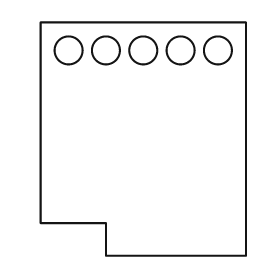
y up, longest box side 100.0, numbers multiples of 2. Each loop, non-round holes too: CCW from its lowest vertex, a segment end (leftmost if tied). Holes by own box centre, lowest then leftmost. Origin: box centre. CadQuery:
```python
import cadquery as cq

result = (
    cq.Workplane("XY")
    .moveTo(-16.0, -50.0)
    .lineTo(44.0, -50.0)
    .lineTo(44.0, 50.0)
    .lineTo(-44.0, 50.0)
    .lineTo(-44.0, -36.0)
    .lineTo(-16.0, -36.0)
    .close()
    .moveTo(-32.0, 38.0)
    .circle(6.0)
    .moveTo(-16.0, 38.0)
    .circle(6.0)
    .moveTo(0.0, 38.0)
    .circle(6.0)
    .moveTo(16.0, 38.0)
    .circle(6.0)
    .moveTo(32.0, 38.0)
    .circle(6.0)
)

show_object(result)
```